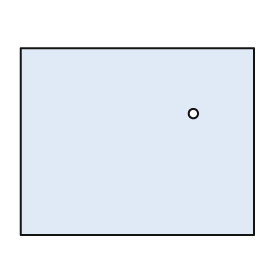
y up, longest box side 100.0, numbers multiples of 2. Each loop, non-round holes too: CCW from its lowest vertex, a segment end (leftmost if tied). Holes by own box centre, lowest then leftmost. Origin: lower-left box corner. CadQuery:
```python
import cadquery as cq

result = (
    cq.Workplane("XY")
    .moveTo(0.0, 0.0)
    .lineTo(100.0, 0.0)
    .lineTo(100.0, 80.0)
    .lineTo(0.0, 80.0)
    .close()
    .moveTo(74.0, 52.0)
    .circle(2.0)
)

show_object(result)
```